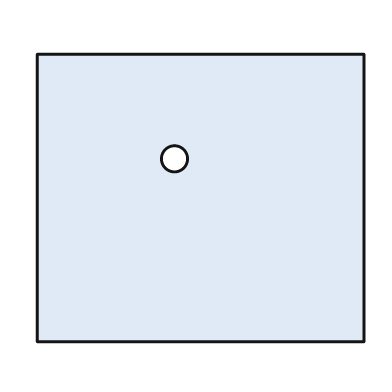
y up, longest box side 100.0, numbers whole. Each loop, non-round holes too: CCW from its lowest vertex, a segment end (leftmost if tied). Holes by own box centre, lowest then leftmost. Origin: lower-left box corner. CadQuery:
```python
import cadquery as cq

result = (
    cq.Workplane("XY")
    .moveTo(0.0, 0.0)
    .lineTo(100.0, 0.0)
    .lineTo(100.0, 88.0)
    .lineTo(0.0, 88.0)
    .close()
    .moveTo(42.0, 56.0)
    .circle(4.0)
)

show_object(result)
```